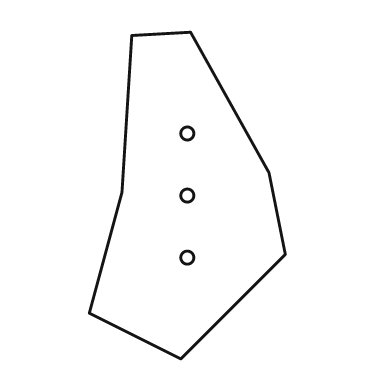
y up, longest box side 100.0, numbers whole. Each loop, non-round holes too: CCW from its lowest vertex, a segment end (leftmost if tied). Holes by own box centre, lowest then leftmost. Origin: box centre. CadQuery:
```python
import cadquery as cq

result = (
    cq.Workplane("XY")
    .moveTo(-2.0, -50.0)
    .lineTo(30.0, -18.0)
    .lineTo(25.0, 7.0)
    .lineTo(1.0, 50.0)
    .lineTo(-17.0, 49.0)
    .lineTo(-20.0, 1.0)
    .lineTo(-30.0, -36.0)
    .close()
    .moveTo(0.0, -19.0)
    .circle(2.0)
    .moveTo(0.0, 0.0)
    .circle(2.0)
    .moveTo(0.0, 19.0)
    .circle(2.0)
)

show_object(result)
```